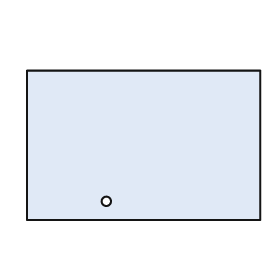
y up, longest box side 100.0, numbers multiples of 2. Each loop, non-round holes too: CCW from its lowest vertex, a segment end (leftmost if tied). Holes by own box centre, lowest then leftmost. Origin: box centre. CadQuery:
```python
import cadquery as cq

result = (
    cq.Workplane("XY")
    .moveTo(-50.0, -32.0)
    .lineTo(50.0, -32.0)
    .lineTo(50.0, 32.0)
    .lineTo(-50.0, 32.0)
    .close()
    .moveTo(-16.0, -24.0)
    .circle(2.0)
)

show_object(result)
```